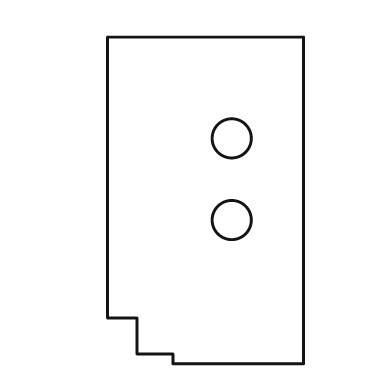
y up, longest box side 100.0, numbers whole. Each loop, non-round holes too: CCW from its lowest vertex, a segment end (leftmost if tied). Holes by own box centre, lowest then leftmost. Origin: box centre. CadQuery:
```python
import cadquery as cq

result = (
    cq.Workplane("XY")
    .moveTo(-10.0, -50.0)
    .lineTo(30.0, -50.0)
    .lineTo(30.0, 50.0)
    .lineTo(-30.0, 50.0)
    .lineTo(-30.0, -36.0)
    .lineTo(-21.0, -36.0)
    .lineTo(-21.0, -47.0)
    .lineTo(-10.0, -47.0)
    .close()
    .moveTo(8.0, -6.0)
    .circle(6.0)
    .moveTo(8.0, 19.0)
    .circle(6.0)
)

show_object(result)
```